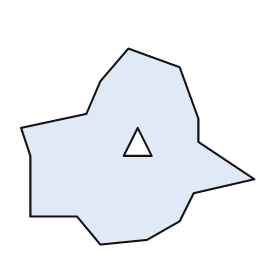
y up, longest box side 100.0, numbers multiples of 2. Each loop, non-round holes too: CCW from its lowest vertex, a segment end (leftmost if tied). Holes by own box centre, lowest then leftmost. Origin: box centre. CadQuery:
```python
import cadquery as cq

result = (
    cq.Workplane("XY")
    .moveTo(-16.0, -42.0)
    .lineTo(4.0, -40.0)
    .lineTo(18.0, -32.0)
    .lineTo(24.0, -20.0)
    .lineTo(50.0, -14.0)
    .lineTo(26.0, 2.0)
    .lineTo(26.0, 12.0)
    .lineTo(18.0, 34.0)
    .lineTo(-4.0, 42.0)
    .lineTo(-16.0, 28.0)
    .lineTo(-22.0, 14.0)
    .lineTo(-50.0, 8.0)
    .lineTo(-46.0, -4.0)
    .lineTo(-46.0, -30.0)
    .lineTo(-26.0, -30.0)
    .close()
    .moveTo(-6.0, -4.0)
    .lineTo(6.0, -4.0)
    .lineTo(0.0, 8.0)
    .close()
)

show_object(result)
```